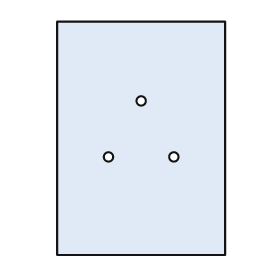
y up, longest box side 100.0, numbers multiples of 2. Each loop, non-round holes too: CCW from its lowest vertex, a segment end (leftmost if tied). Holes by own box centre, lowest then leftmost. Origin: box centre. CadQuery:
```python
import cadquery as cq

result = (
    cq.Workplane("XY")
    .moveTo(-36.0, -50.0)
    .lineTo(36.0, -50.0)
    .lineTo(36.0, 50.0)
    .lineTo(-36.0, 50.0)
    .close()
    .moveTo(-14.0, -8.0)
    .circle(2.0)
    .moveTo(14.0, -8.0)
    .circle(2.0)
    .moveTo(0.0, 16.0)
    .circle(2.0)
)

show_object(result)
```